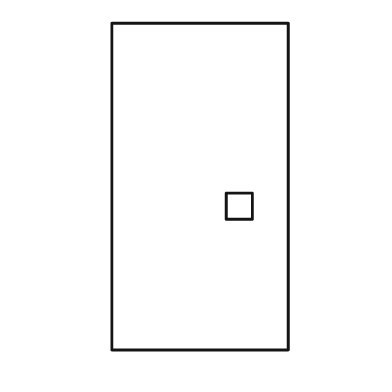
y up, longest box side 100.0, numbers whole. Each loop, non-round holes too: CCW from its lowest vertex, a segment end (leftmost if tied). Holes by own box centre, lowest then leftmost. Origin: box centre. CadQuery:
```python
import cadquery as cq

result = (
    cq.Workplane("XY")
    .moveTo(-27.0, -50.0)
    .lineTo(27.0, -50.0)
    .lineTo(27.0, 50.0)
    .lineTo(-27.0, 50.0)
    .close()
    .moveTo(8.0, -10.0)
    .lineTo(16.0, -10.0)
    .lineTo(16.0, -2.0)
    .lineTo(8.0, -2.0)
    .close()
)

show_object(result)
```